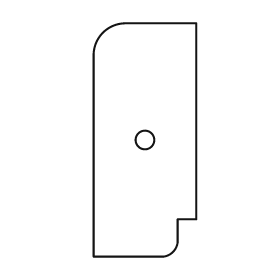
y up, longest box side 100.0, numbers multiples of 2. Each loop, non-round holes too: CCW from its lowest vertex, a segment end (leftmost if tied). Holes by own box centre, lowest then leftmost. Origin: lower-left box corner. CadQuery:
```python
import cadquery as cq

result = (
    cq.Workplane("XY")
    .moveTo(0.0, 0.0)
    .lineTo(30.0, 0.0)
    .threePointArc((34.0, 2.0), (36.0, 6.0))
    .lineTo(36.0, 16.0)
    .lineTo(44.0, 16.0)
    .lineTo(44.0, 100.0)
    .lineTo(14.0, 100.0)
    .threePointArc((4.0, 96.0), (0.0, 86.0))
    .close()
    .moveTo(22.0, 50.0)
    .circle(4.0)
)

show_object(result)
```